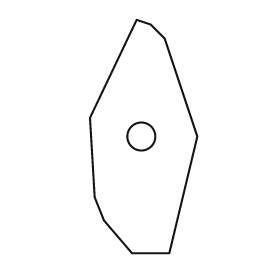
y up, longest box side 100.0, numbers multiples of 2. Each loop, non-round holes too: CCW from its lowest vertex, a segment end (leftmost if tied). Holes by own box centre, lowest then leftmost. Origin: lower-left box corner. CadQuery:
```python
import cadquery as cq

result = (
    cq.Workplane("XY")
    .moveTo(18.0, 0.0)
    .lineTo(34.0, 0.0)
    .lineTo(46.0, 50.0)
    .lineTo(32.0, 92.0)
    .lineTo(26.0, 98.0)
    .lineTo(20.0, 100.0)
    .lineTo(0.0, 58.0)
    .lineTo(2.0, 24.0)
    .lineTo(6.0, 14.0)
    .close()
    .moveTo(22.0, 50.0)
    .circle(6.0)
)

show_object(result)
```